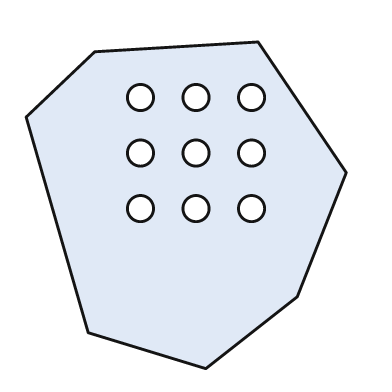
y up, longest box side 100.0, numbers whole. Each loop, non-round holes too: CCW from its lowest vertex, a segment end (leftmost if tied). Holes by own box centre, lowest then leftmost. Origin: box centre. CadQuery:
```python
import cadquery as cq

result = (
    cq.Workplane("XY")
    .moveTo(6.0, -50.0)
    .lineTo(34.0, -28.0)
    .lineTo(49.0, 10.0)
    .lineTo(22.0, 50.0)
    .lineTo(-28.0, 47.0)
    .lineTo(-49.0, 27.0)
    .lineTo(-30.0, -39.0)
    .close()
    .moveTo(-14.0, -1.0)
    .circle(4.0)
    .moveTo(3.0, -1.0)
    .circle(4.0)
    .moveTo(20.0, -1.0)
    .circle(4.0)
    .moveTo(-14.0, 16.0)
    .circle(4.0)
    .moveTo(3.0, 16.0)
    .circle(4.0)
    .moveTo(20.0, 16.0)
    .circle(4.0)
    .moveTo(-14.0, 33.0)
    .circle(4.0)
    .moveTo(3.0, 33.0)
    .circle(4.0)
    .moveTo(20.0, 33.0)
    .circle(4.0)
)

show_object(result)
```